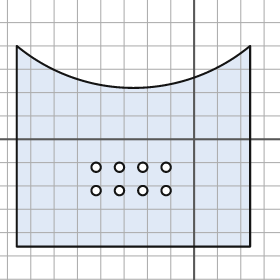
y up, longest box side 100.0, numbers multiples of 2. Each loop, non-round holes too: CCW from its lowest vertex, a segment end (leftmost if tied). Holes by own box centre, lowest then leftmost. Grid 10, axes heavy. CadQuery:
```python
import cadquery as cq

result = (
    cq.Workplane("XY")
    .moveTo(-76.0, -46.0)
    .lineTo(24.0, -46.0)
    .lineTo(24.0, 40.0)
    .threePointArc((-26.0, 22.0), (-76.0, 40.0))
    .close()
    .moveTo(-42.0, -22.0)
    .circle(2.0)
    .moveTo(-32.0, -22.0)
    .circle(2.0)
    .moveTo(-22.0, -22.0)
    .circle(2.0)
    .moveTo(-12.0, -22.0)
    .circle(2.0)
    .moveTo(-42.0, -12.0)
    .circle(2.0)
    .moveTo(-32.0, -12.0)
    .circle(2.0)
    .moveTo(-22.0, -12.0)
    .circle(2.0)
    .moveTo(-12.0, -12.0)
    .circle(2.0)
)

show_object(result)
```